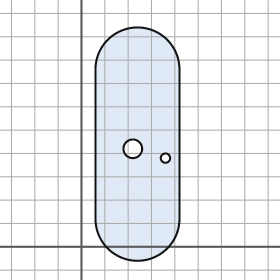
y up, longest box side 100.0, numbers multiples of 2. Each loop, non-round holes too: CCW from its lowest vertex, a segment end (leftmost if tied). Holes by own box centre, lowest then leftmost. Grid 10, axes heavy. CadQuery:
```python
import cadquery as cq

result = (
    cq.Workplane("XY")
    .moveTo(6.0, 12.0)
    .threePointArc((24.0, -6.0), (42.0, 12.0))
    .lineTo(42.0, 76.0)
    .threePointArc((24.0, 94.0), (6.0, 76.0))
    .close()
    .moveTo(36.0, 38.0)
    .circle(2.0)
    .moveTo(22.0, 42.0)
    .circle(4.0)
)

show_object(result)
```